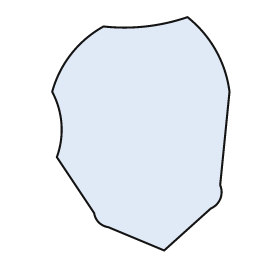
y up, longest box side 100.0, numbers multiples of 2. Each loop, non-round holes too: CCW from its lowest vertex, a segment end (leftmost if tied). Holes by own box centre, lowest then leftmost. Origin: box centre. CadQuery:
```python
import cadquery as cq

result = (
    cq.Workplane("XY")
    .moveTo(10.0, -50.0)
    .lineTo(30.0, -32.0)
    .threePointArc((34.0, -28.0), (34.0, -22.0))
    .lineTo(38.0, 18.0)
    .threePointArc((32.0, 36.0), (20.0, 50.0))
    .threePointArc((2.0, 46.0), (-16.0, 46.0))
    .threePointArc((-30.0, 34.0), (-38.0, 18.0))
    .threePointArc((-34.0, 4.0), (-36.0, -10.0))
    .lineTo(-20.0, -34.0)
    .threePointArc((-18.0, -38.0), (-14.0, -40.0))
    .close()
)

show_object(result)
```